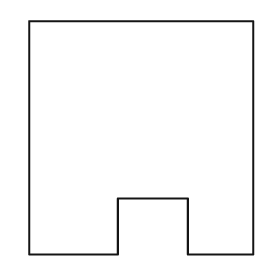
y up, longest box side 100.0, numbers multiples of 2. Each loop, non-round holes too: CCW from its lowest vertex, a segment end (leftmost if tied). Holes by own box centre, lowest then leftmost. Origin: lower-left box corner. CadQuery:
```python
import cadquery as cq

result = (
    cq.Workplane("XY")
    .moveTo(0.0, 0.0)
    .lineTo(38.0, 0.0)
    .lineTo(38.0, 24.0)
    .lineTo(68.0, 24.0)
    .lineTo(68.0, 0.0)
    .lineTo(96.0, 0.0)
    .lineTo(96.0, 100.0)
    .lineTo(0.0, 100.0)
    .close()
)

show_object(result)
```